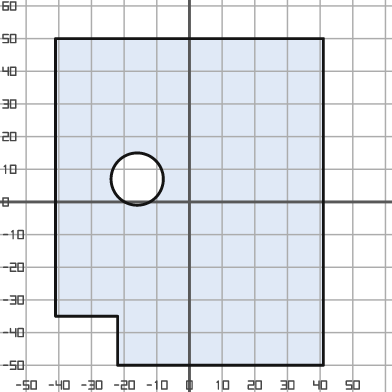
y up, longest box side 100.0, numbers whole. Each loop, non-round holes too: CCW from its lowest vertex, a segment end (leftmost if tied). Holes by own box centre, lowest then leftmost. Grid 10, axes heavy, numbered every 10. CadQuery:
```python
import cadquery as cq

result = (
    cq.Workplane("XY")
    .moveTo(-22.0, -50.0)
    .lineTo(41.0, -50.0)
    .lineTo(41.0, 50.0)
    .lineTo(-41.0, 50.0)
    .lineTo(-41.0, -35.0)
    .lineTo(-22.0, -35.0)
    .close()
    .moveTo(-16.0, 7.0)
    .circle(8.0)
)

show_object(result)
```